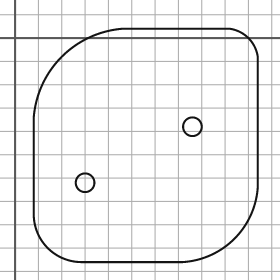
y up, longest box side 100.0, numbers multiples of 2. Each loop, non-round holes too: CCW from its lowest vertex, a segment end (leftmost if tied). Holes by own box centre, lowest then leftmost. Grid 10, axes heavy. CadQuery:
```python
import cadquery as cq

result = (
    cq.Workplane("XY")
    .moveTo(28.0, -96.0)
    .lineTo(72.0, -96.0)
    .threePointArc((94.0, -86.0), (104.0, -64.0))
    .lineTo(104.0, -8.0)
    .threePointArc((100.0, 0.0), (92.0, 4.0))
    .lineTo(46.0, 4.0)
    .threePointArc((20.0, -8.0), (8.0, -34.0))
    .lineTo(8.0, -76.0)
    .threePointArc((14.0, -90.0), (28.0, -96.0))
    .close()
    .moveTo(30.0, -62.0)
    .circle(4.0)
    .moveTo(76.0, -38.0)
    .circle(4.0)
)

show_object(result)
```